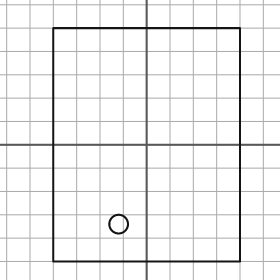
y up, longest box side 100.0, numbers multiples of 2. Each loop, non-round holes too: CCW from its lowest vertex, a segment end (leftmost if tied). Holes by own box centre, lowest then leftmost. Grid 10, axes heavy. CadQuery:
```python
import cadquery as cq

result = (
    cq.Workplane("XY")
    .moveTo(-40.0, -50.0)
    .lineTo(40.0, -50.0)
    .lineTo(40.0, 50.0)
    .lineTo(-40.0, 50.0)
    .close()
    .moveTo(-12.0, -34.0)
    .circle(4.0)
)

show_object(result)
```